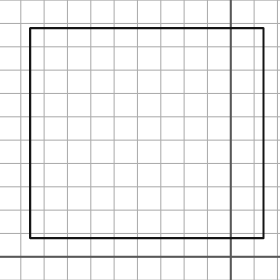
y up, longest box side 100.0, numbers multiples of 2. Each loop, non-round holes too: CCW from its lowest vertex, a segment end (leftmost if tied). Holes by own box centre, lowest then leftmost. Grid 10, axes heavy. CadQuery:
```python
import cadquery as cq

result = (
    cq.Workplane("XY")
    .moveTo(-86.0, 8.0)
    .lineTo(14.0, 8.0)
    .lineTo(14.0, 98.0)
    .lineTo(-86.0, 98.0)
    .close()
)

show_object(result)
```